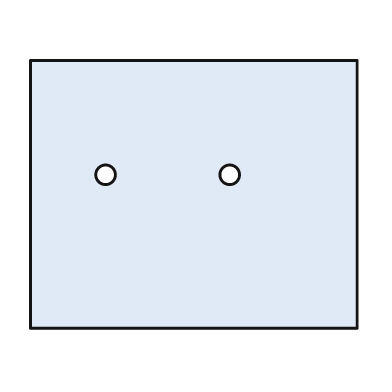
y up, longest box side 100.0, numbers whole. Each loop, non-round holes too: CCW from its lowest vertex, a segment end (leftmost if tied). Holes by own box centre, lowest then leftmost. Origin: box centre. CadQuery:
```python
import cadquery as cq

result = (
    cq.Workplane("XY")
    .moveTo(-50.0, -41.0)
    .lineTo(50.0, -41.0)
    .lineTo(50.0, 41.0)
    .lineTo(-50.0, 41.0)
    .close()
    .moveTo(-27.0, 6.0)
    .circle(3.0)
    .moveTo(11.0, 6.0)
    .circle(3.0)
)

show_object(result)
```